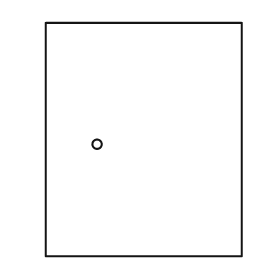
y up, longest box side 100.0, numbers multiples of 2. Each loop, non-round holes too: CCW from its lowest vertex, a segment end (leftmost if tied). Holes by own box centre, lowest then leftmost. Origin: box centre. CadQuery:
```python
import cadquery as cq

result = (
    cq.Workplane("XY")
    .moveTo(-42.0, -50.0)
    .lineTo(42.0, -50.0)
    .lineTo(42.0, 50.0)
    .lineTo(-42.0, 50.0)
    .close()
    .moveTo(-20.0, -2.0)
    .circle(2.0)
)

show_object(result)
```